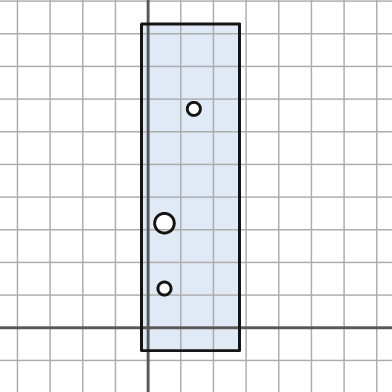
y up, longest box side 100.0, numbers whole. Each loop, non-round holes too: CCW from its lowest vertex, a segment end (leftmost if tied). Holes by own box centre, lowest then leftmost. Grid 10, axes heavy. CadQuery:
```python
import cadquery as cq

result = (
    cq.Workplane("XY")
    .moveTo(-2.0, -7.0)
    .lineTo(28.0, -7.0)
    .lineTo(28.0, 93.0)
    .lineTo(-2.0, 93.0)
    .close()
    .moveTo(5.0, 12.0)
    .circle(2.0)
    .moveTo(5.0, 32.0)
    .circle(3.0)
    .moveTo(14.0, 67.0)
    .circle(2.0)
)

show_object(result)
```